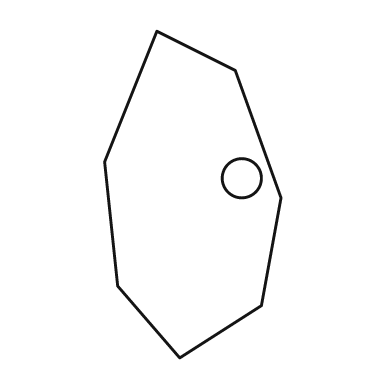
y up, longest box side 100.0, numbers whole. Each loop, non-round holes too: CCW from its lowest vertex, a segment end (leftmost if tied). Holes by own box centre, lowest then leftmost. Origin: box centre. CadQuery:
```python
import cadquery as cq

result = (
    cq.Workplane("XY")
    .moveTo(-4.0, -50.0)
    .lineTo(21.0, -34.0)
    .lineTo(27.0, -1.0)
    .lineTo(13.0, 38.0)
    .lineTo(-11.0, 50.0)
    .lineTo(-27.0, 10.0)
    .lineTo(-23.0, -28.0)
    .close()
    .moveTo(15.0, 5.0)
    .circle(6.0)
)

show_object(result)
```